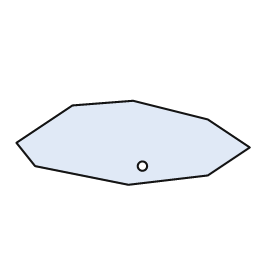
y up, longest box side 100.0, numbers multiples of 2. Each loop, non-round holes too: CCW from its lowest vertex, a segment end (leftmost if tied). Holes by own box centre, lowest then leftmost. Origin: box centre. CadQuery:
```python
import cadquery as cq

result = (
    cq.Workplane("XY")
    .moveTo(-2.0, -18.0)
    .lineTo(32.0, -14.0)
    .lineTo(50.0, -2.0)
    .lineTo(32.0, 10.0)
    .lineTo(0.0, 18.0)
    .lineTo(-26.0, 16.0)
    .lineTo(-50.0, 0.0)
    .lineTo(-42.0, -10.0)
    .close()
    .moveTo(4.0, -10.0)
    .circle(2.0)
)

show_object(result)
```